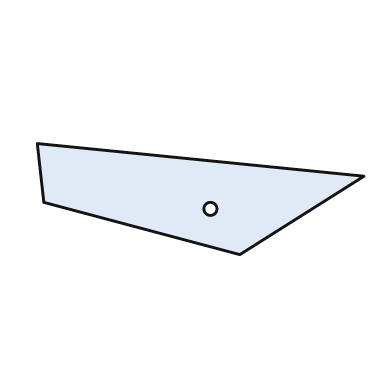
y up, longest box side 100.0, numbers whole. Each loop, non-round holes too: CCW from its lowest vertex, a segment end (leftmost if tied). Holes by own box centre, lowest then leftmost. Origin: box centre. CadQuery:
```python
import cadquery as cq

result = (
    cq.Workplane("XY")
    .moveTo(12.0, -17.0)
    .lineTo(50.0, 7.0)
    .lineTo(-50.0, 17.0)
    .lineTo(-48.0, -1.0)
    .close()
    .moveTo(3.0, -3.0)
    .circle(2.0)
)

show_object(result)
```